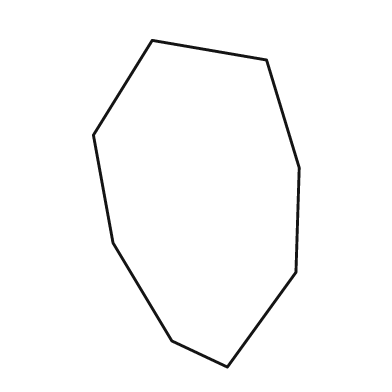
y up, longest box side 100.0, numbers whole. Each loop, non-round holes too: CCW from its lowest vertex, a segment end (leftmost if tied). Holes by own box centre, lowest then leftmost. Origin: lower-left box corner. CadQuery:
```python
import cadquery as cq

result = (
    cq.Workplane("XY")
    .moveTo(41.0, 0.0)
    .lineTo(62.0, 29.0)
    .lineTo(63.0, 61.0)
    .lineTo(53.0, 94.0)
    .lineTo(18.0, 100.0)
    .lineTo(0.0, 71.0)
    .lineTo(6.0, 38.0)
    .lineTo(24.0, 8.0)
    .close()
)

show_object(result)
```